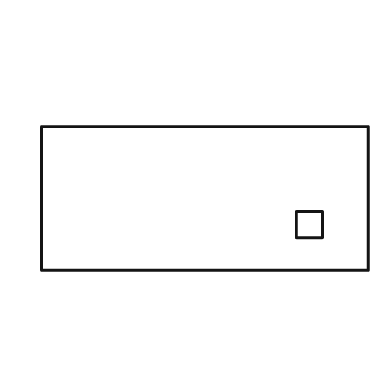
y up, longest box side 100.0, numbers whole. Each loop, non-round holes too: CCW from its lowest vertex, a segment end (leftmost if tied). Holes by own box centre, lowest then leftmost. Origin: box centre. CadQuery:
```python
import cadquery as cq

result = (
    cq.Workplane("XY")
    .moveTo(-50.0, -22.0)
    .lineTo(50.0, -22.0)
    .lineTo(50.0, 22.0)
    .lineTo(-50.0, 22.0)
    .close()
    .moveTo(28.0, -12.0)
    .lineTo(36.0, -12.0)
    .lineTo(36.0, -4.0)
    .lineTo(28.0, -4.0)
    .close()
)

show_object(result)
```